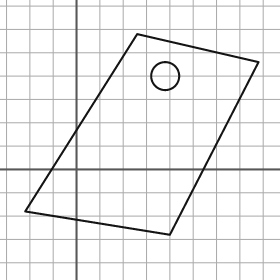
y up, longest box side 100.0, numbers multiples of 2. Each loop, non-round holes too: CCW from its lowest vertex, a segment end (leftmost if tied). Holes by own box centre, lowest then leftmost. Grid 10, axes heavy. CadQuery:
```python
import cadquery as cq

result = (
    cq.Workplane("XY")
    .moveTo(40.0, -28.0)
    .lineTo(78.0, 46.0)
    .lineTo(26.0, 58.0)
    .lineTo(-22.0, -18.0)
    .close()
    .moveTo(38.0, 40.0)
    .circle(6.0)
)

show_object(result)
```